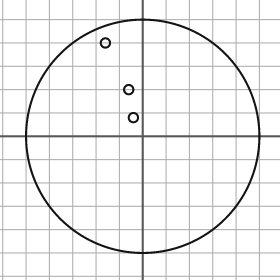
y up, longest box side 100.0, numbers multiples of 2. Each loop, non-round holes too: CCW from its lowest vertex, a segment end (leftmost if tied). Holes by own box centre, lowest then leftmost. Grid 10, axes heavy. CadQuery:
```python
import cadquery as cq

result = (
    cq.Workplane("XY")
    .moveTo(0.0, 0.0)
    .circle(50.0)
    .moveTo(-4.0, 8.0)
    .circle(2.0)
    .moveTo(-6.0, 20.0)
    .circle(2.0)
    .moveTo(-16.0, 40.0)
    .circle(2.0)
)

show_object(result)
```